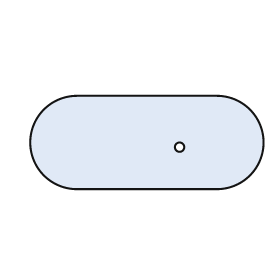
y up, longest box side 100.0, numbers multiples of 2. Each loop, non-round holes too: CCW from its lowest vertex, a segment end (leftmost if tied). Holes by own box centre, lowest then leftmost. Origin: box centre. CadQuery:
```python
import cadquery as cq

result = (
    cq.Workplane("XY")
    .moveTo(-30.0, -20.0)
    .lineTo(30.0, -20.0)
    .threePointArc((50.0, 0.0), (30.0, 20.0))
    .lineTo(-30.0, 20.0)
    .threePointArc((-50.0, 0.0), (-30.0, -20.0))
    .close()
    .moveTo(14.0, -2.0)
    .circle(2.0)
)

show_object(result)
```